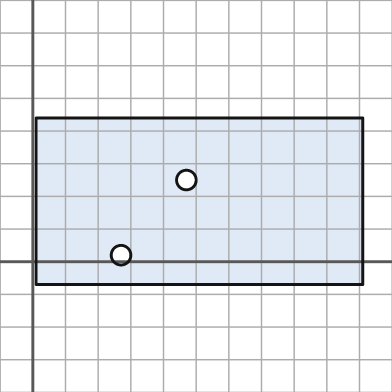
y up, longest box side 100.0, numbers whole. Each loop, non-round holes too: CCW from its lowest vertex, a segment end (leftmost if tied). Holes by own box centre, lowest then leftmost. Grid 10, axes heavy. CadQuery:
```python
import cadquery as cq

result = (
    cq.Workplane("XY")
    .moveTo(1.0, -7.0)
    .lineTo(101.0, -7.0)
    .lineTo(101.0, 44.0)
    .lineTo(1.0, 44.0)
    .close()
    .moveTo(27.0, 2.0)
    .circle(3.0)
    .moveTo(47.0, 25.0)
    .circle(3.0)
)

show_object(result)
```